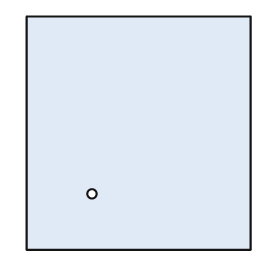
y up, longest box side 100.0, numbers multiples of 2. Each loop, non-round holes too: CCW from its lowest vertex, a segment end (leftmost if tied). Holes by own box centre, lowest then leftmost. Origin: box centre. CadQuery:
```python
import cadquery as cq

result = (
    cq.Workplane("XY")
    .moveTo(-48.0, -50.0)
    .lineTo(48.0, -50.0)
    .lineTo(48.0, 50.0)
    .lineTo(-48.0, 50.0)
    .close()
    .moveTo(-20.0, -26.0)
    .circle(2.0)
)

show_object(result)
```